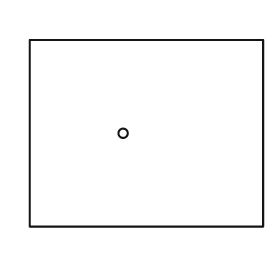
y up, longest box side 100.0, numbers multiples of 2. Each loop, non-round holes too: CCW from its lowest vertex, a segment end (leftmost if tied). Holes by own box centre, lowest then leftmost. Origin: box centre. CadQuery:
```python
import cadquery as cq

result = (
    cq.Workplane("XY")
    .moveTo(-50.0, -40.0)
    .lineTo(50.0, -40.0)
    .lineTo(50.0, 40.0)
    .lineTo(-50.0, 40.0)
    .close()
    .moveTo(-10.0, 0.0)
    .circle(2.0)
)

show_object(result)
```